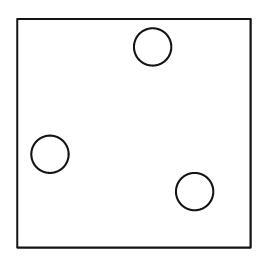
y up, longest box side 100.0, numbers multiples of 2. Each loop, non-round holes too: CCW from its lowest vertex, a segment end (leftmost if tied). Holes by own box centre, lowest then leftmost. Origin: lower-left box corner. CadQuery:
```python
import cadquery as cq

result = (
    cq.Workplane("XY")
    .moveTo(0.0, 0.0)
    .lineTo(100.0, 0.0)
    .lineTo(100.0, 98.0)
    .lineTo(0.0, 98.0)
    .close()
    .moveTo(76.0, 24.0)
    .circle(8.0)
    .moveTo(14.0, 40.0)
    .circle(8.0)
    .moveTo(58.0, 86.0)
    .circle(8.0)
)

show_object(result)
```